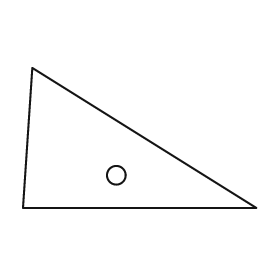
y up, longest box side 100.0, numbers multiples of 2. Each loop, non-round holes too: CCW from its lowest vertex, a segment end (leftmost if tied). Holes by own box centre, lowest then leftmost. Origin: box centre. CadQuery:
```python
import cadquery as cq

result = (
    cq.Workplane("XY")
    .moveTo(-50.0, -30.0)
    .lineTo(50.0, -30.0)
    .lineTo(-46.0, 30.0)
    .close()
    .moveTo(-10.0, -16.0)
    .circle(4.0)
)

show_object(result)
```